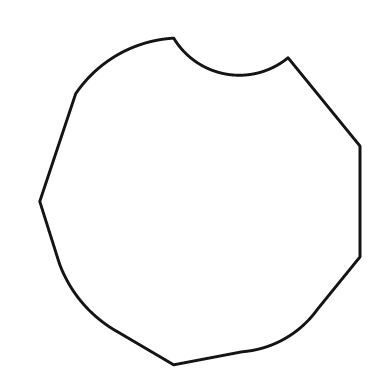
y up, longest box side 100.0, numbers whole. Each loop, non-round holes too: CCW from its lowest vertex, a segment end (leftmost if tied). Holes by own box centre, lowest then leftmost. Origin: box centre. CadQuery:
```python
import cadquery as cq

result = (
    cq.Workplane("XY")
    .moveTo(-8.0, -50.0)
    .lineTo(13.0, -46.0)
    .threePointArc((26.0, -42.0), (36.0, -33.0))
    .lineTo(49.0, -17.0)
    .lineTo(49.0, 17.0)
    .lineTo(27.0, 44.0)
    .threePointArc((8.0, 39.0), (-8.0, 50.0))
    .threePointArc((-25.0, 45.0), (-38.0, 33.0))
    .lineTo(-49.0, 0.0)
    .lineTo(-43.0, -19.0)
    .threePointArc((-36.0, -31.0), (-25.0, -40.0))
    .close()
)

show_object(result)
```